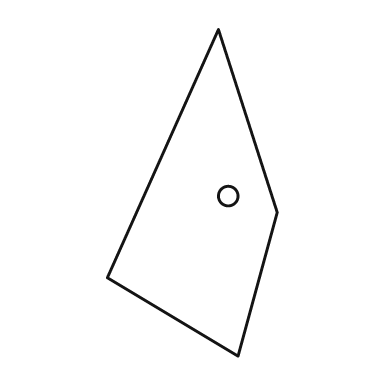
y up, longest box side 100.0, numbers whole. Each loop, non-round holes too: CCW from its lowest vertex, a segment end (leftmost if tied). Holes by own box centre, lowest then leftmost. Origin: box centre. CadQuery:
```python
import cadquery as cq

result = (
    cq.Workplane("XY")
    .moveTo(14.0, -50.0)
    .lineTo(26.0, -6.0)
    .lineTo(8.0, 50.0)
    .lineTo(-26.0, -26.0)
    .close()
    .moveTo(11.0, -1.0)
    .circle(3.0)
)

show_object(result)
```